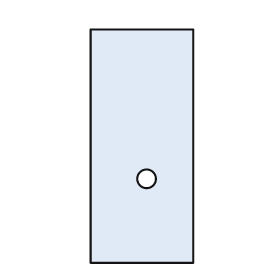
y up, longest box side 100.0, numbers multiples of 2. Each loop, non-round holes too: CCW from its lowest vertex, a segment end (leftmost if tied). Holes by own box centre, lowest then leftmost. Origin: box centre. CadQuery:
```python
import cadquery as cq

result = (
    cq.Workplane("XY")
    .moveTo(-22.0, -50.0)
    .lineTo(22.0, -50.0)
    .lineTo(22.0, 50.0)
    .lineTo(-22.0, 50.0)
    .close()
    .moveTo(2.0, -14.0)
    .circle(4.0)
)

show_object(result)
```